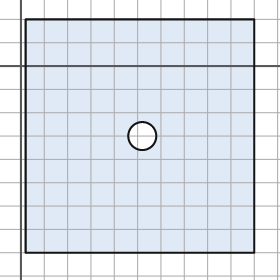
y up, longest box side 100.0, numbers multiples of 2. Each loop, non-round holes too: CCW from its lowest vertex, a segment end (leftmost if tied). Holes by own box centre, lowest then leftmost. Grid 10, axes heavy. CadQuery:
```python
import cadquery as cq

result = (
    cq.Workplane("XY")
    .moveTo(2.0, -80.0)
    .lineTo(100.0, -80.0)
    .lineTo(100.0, 20.0)
    .lineTo(2.0, 20.0)
    .close()
    .moveTo(52.0, -30.0)
    .circle(6.0)
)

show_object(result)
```